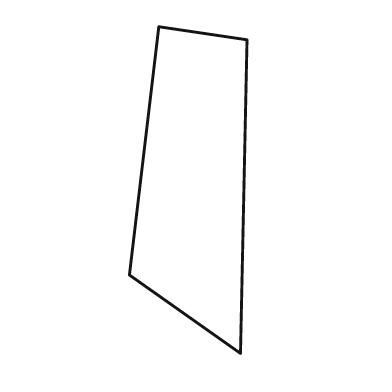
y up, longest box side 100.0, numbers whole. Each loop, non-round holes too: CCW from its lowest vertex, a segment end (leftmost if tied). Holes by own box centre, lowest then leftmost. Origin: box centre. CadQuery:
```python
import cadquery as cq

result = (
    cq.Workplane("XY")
    .moveTo(16.0, -50.0)
    .lineTo(18.0, 46.0)
    .lineTo(-9.0, 50.0)
    .lineTo(-18.0, -26.0)
    .close()
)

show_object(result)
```